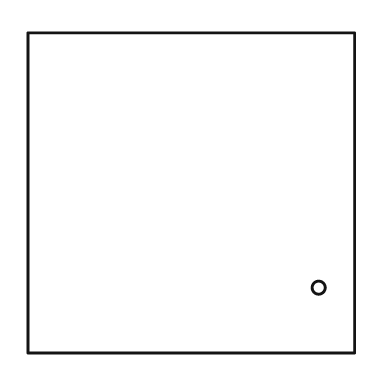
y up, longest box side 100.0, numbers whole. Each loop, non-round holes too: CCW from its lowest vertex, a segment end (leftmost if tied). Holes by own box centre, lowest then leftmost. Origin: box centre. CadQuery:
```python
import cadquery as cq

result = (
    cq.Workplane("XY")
    .moveTo(-50.0, -49.0)
    .lineTo(50.0, -49.0)
    .lineTo(50.0, 49.0)
    .lineTo(-50.0, 49.0)
    .close()
    .moveTo(39.0, -29.0)
    .circle(2.0)
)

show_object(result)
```